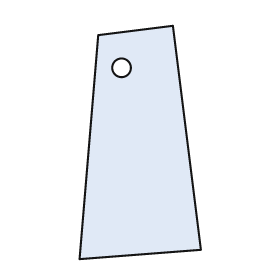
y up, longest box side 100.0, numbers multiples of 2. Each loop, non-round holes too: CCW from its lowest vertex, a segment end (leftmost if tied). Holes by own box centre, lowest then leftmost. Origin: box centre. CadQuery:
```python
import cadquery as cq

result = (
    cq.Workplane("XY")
    .moveTo(-26.0, -50.0)
    .lineTo(26.0, -46.0)
    .lineTo(14.0, 50.0)
    .lineTo(-18.0, 46.0)
    .close()
    .moveTo(-8.0, 32.0)
    .circle(4.0)
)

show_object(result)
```